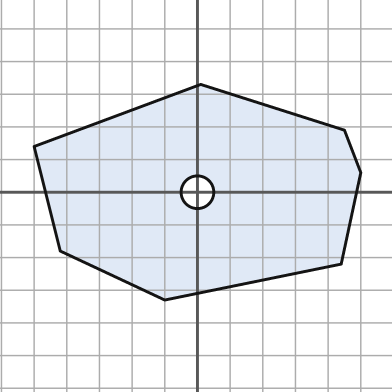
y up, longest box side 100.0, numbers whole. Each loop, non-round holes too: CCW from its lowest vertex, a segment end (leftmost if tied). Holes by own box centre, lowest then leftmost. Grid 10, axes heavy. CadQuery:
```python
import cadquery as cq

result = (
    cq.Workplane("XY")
    .moveTo(-10.0, -33.0)
    .lineTo(44.0, -22.0)
    .lineTo(50.0, 6.0)
    .lineTo(45.0, 19.0)
    .lineTo(1.0, 33.0)
    .lineTo(-50.0, 14.0)
    .lineTo(-42.0, -18.0)
    .close()
    .moveTo(0.0, 0.0)
    .circle(5.0)
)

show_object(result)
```